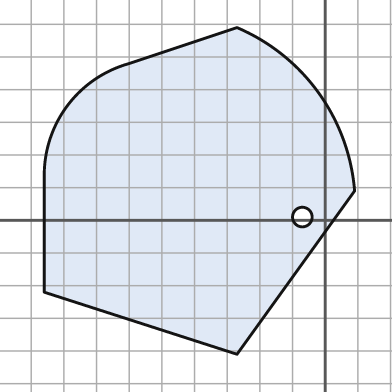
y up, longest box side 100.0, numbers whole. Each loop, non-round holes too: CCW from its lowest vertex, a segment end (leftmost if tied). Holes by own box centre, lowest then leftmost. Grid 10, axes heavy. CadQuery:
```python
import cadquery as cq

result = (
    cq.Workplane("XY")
    .moveTo(-27.0, -41.0)
    .lineTo(9.0, 9.0)
    .threePointArc((-2.0, 39.0), (-27.0, 59.0))
    .lineTo(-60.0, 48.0)
    .threePointArc((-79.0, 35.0), (-86.0, 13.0))
    .lineTo(-86.0, -22.0)
    .close()
    .moveTo(-7.0, 1.0)
    .circle(3.0)
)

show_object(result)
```